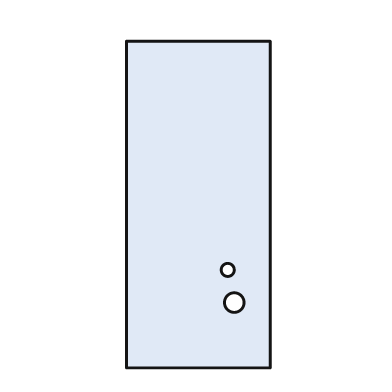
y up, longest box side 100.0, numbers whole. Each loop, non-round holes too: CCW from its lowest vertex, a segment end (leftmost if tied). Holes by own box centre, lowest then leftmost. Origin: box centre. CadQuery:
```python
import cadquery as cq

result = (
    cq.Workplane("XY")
    .moveTo(-22.0, -50.0)
    .lineTo(22.0, -50.0)
    .lineTo(22.0, 50.0)
    .lineTo(-22.0, 50.0)
    .close()
    .moveTo(11.0, -30.0)
    .circle(3.0)
    .moveTo(9.0, -20.0)
    .circle(2.0)
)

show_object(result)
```